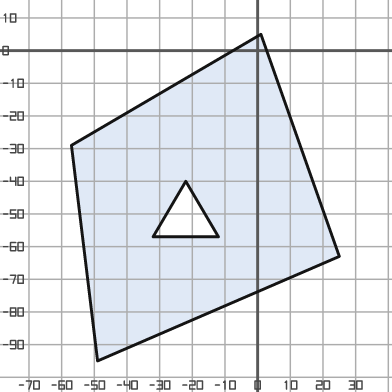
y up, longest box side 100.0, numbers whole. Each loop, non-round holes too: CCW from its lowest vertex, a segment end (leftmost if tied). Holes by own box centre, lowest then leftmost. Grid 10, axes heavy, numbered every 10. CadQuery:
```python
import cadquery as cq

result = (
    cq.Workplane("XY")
    .moveTo(-49.0, -95.0)
    .lineTo(25.0, -63.0)
    .lineTo(1.0, 5.0)
    .lineTo(-57.0, -29.0)
    .close()
    .moveTo(-32.0, -57.0)
    .lineTo(-12.0, -57.0)
    .lineTo(-22.0, -40.0)
    .close()
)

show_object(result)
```